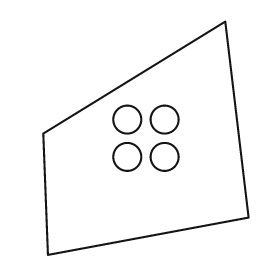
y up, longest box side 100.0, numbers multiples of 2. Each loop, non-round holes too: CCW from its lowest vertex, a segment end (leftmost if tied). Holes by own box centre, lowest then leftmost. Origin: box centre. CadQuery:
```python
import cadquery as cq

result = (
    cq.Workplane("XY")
    .moveTo(-42.0, -50.0)
    .lineTo(44.0, -34.0)
    .lineTo(34.0, 50.0)
    .lineTo(-44.0, 2.0)
    .close()
    .moveTo(-8.0, -8.0)
    .circle(6.0)
    .moveTo(8.0, -8.0)
    .circle(6.0)
    .moveTo(-8.0, 8.0)
    .circle(6.0)
    .moveTo(8.0, 8.0)
    .circle(6.0)
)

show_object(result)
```